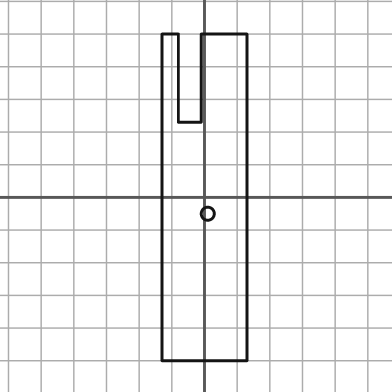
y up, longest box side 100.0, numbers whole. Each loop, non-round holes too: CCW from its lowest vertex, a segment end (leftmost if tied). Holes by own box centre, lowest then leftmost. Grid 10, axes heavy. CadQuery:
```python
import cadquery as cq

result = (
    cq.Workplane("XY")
    .moveTo(-13.0, -50.0)
    .lineTo(13.0, -50.0)
    .lineTo(13.0, 50.0)
    .lineTo(-1.0, 50.0)
    .lineTo(-1.0, 23.0)
    .lineTo(-8.0, 23.0)
    .lineTo(-8.0, 50.0)
    .lineTo(-13.0, 50.0)
    .close()
    .moveTo(1.0, -5.0)
    .circle(2.0)
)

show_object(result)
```